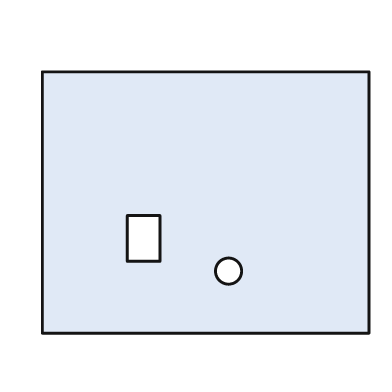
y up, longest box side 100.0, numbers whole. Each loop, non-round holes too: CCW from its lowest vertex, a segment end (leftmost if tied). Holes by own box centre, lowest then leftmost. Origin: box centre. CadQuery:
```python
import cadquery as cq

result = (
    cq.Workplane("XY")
    .moveTo(-50.0, -40.0)
    .lineTo(50.0, -40.0)
    .lineTo(50.0, 40.0)
    .lineTo(-50.0, 40.0)
    .close()
    .moveTo(7.0, -21.0)
    .circle(4.0)
    .moveTo(-24.0, -18.0)
    .lineTo(-14.0, -18.0)
    .lineTo(-14.0, -4.0)
    .lineTo(-24.0, -4.0)
    .close()
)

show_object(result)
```